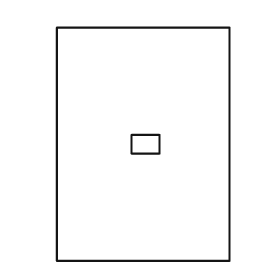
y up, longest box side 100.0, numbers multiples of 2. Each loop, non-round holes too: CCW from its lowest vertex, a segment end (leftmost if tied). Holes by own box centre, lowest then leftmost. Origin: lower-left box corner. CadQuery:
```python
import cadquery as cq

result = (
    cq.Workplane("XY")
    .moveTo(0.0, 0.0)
    .lineTo(74.0, 0.0)
    .lineTo(74.0, 100.0)
    .lineTo(0.0, 100.0)
    .close()
    .moveTo(32.0, 46.0)
    .lineTo(44.0, 46.0)
    .lineTo(44.0, 54.0)
    .lineTo(32.0, 54.0)
    .close()
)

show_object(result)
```